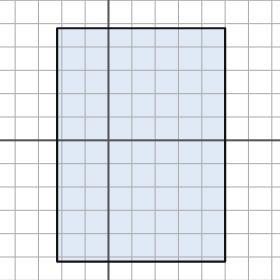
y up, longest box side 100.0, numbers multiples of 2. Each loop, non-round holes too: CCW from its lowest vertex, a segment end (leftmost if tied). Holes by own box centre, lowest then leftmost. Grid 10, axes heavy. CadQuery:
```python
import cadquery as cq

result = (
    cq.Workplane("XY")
    .moveTo(-22.0, -52.0)
    .lineTo(50.0, -52.0)
    .lineTo(50.0, 48.0)
    .lineTo(-22.0, 48.0)
    .close()
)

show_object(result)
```